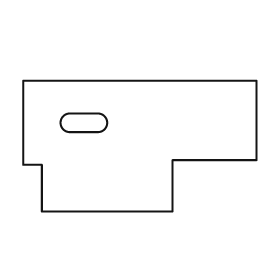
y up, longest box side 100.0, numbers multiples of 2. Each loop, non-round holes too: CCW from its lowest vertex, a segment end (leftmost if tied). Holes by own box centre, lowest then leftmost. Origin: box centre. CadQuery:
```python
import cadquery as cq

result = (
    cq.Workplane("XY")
    .moveTo(-42.0, -28.0)
    .lineTo(14.0, -28.0)
    .lineTo(14.0, -6.0)
    .lineTo(50.0, -6.0)
    .lineTo(50.0, 28.0)
    .lineTo(-50.0, 28.0)
    .lineTo(-50.0, -8.0)
    .lineTo(-42.0, -8.0)
    .close()
    .moveTo(-30.0, 6.0)
    .lineTo(-18.0, 6.0)
    .threePointArc((-14.0, 10.0), (-18.0, 14.0))
    .lineTo(-30.0, 14.0)
    .threePointArc((-34.0, 10.0), (-30.0, 6.0))
    .close()
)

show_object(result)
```